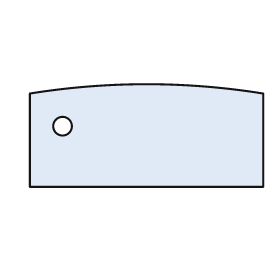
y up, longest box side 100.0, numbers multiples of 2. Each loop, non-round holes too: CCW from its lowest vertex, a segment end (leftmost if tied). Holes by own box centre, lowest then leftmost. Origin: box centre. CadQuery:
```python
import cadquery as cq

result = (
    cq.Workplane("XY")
    .moveTo(-50.0, -22.0)
    .lineTo(50.0, -22.0)
    .lineTo(50.0, 18.0)
    .threePointArc((0.0, 22.0), (-50.0, 18.0))
    .close()
    .moveTo(-36.0, 4.0)
    .circle(4.0)
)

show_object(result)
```